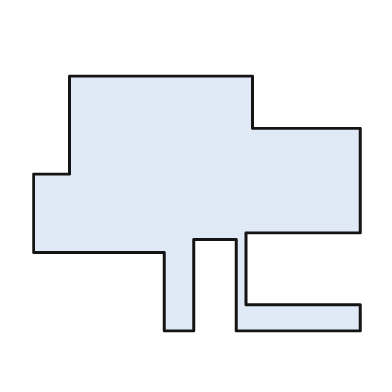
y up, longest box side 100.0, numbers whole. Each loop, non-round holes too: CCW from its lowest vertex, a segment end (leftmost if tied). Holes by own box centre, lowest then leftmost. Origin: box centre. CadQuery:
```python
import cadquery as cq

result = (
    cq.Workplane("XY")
    .moveTo(-10.0, -39.0)
    .lineTo(-1.0, -39.0)
    .lineTo(-1.0, -11.0)
    .lineTo(12.0, -11.0)
    .lineTo(12.0, -39.0)
    .lineTo(50.0, -39.0)
    .lineTo(50.0, -31.0)
    .lineTo(15.0, -31.0)
    .lineTo(15.0, -9.0)
    .lineTo(50.0, -9.0)
    .lineTo(50.0, 23.0)
    .lineTo(17.0, 23.0)
    .lineTo(17.0, 39.0)
    .lineTo(-39.0, 39.0)
    .lineTo(-39.0, 9.0)
    .lineTo(-50.0, 9.0)
    .lineTo(-50.0, -15.0)
    .lineTo(-10.0, -15.0)
    .close()
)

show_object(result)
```